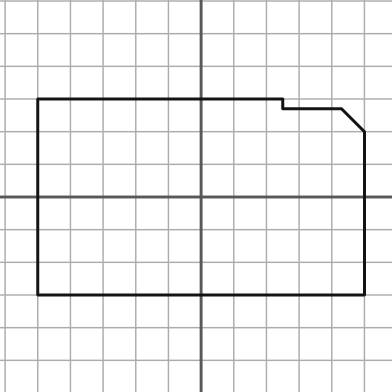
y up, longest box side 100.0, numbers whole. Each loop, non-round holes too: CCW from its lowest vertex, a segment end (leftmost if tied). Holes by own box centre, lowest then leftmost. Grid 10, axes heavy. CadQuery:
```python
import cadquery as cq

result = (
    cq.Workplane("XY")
    .moveTo(-50.0, -30.0)
    .lineTo(50.0, -30.0)
    .lineTo(50.0, 20.0)
    .lineTo(43.0, 27.0)
    .lineTo(25.0, 27.0)
    .lineTo(25.0, 30.0)
    .lineTo(-50.0, 30.0)
    .close()
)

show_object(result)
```